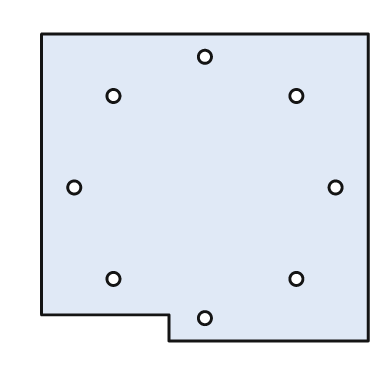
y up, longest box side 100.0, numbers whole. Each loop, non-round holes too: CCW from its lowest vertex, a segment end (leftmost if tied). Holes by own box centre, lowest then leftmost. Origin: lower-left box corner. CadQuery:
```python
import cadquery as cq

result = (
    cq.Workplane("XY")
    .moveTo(39.0, 0.0)
    .lineTo(100.0, 0.0)
    .lineTo(100.0, 94.0)
    .lineTo(0.0, 94.0)
    .lineTo(0.0, 8.0)
    .lineTo(39.0, 8.0)
    .close()
    .moveTo(50.0, 7.0)
    .circle(2.0)
    .moveTo(22.0, 19.0)
    .circle(2.0)
    .moveTo(78.0, 19.0)
    .circle(2.0)
    .moveTo(10.0, 47.0)
    .circle(2.0)
    .moveTo(90.0, 47.0)
    .circle(2.0)
    .moveTo(22.0, 75.0)
    .circle(2.0)
    .moveTo(78.0, 75.0)
    .circle(2.0)
    .moveTo(50.0, 87.0)
    .circle(2.0)
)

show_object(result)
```